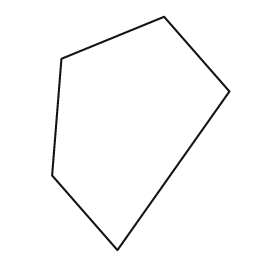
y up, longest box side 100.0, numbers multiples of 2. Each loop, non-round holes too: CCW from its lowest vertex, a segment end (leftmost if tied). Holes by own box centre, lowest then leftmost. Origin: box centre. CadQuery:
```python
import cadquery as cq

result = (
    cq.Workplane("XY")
    .moveTo(-10.0, -50.0)
    .lineTo(38.0, 18.0)
    .lineTo(10.0, 50.0)
    .lineTo(-34.0, 32.0)
    .lineTo(-38.0, -18.0)
    .close()
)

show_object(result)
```